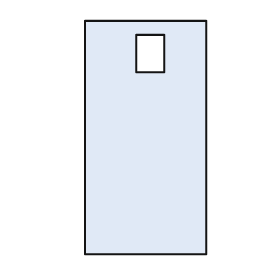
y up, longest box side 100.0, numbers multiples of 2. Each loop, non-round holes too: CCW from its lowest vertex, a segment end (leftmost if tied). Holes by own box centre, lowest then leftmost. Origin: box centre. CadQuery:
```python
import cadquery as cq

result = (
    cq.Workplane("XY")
    .moveTo(-26.0, -50.0)
    .lineTo(26.0, -50.0)
    .lineTo(26.0, 50.0)
    .lineTo(-26.0, 50.0)
    .close()
    .moveTo(-4.0, 28.0)
    .lineTo(8.0, 28.0)
    .lineTo(8.0, 44.0)
    .lineTo(-4.0, 44.0)
    .close()
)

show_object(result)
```